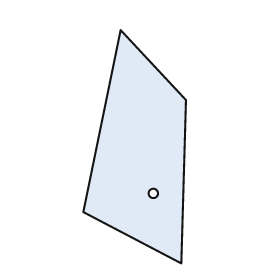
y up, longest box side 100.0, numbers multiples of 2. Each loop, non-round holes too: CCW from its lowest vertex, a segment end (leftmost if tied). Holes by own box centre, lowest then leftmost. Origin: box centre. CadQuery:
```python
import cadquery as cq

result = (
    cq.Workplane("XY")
    .moveTo(20.0, -50.0)
    .lineTo(22.0, 20.0)
    .lineTo(-6.0, 50.0)
    .lineTo(-22.0, -28.0)
    .close()
    .moveTo(8.0, -20.0)
    .circle(2.0)
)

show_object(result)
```